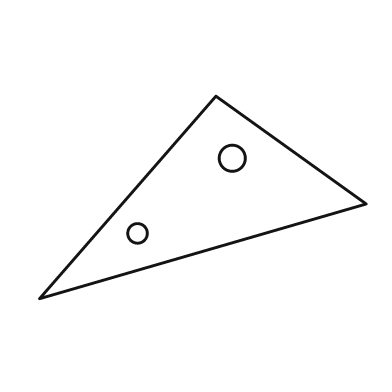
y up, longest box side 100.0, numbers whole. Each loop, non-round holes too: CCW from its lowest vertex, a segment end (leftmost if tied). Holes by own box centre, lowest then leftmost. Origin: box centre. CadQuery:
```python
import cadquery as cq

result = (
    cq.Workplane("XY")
    .moveTo(-50.0, -31.0)
    .lineTo(50.0, -2.0)
    .lineTo(4.0, 31.0)
    .close()
    .moveTo(-20.0, -11.0)
    .circle(3.0)
    .moveTo(9.0, 12.0)
    .circle(4.0)
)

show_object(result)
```